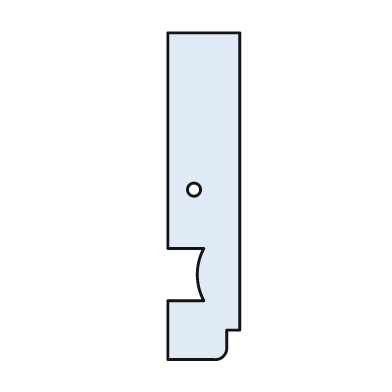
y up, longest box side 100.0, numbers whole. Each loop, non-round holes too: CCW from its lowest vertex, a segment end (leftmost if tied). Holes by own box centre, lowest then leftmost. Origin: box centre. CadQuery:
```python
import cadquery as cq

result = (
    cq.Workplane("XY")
    .moveTo(-11.0, -50.0)
    .lineTo(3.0, -50.0)
    .threePointArc((6.0, -49.0), (7.0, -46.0))
    .lineTo(7.0, -41.0)
    .lineTo(11.0, -41.0)
    .lineTo(11.0, 50.0)
    .lineTo(-11.0, 50.0)
    .lineTo(-11.0, -16.0)
    .lineTo(0.0, -16.0)
    .threePointArc((-2.0, -24.0), (0.0, -32.0))
    .lineTo(-11.0, -32.0)
    .close()
    .moveTo(-3.0, 2.0)
    .circle(2.0)
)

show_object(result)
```